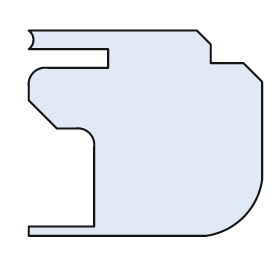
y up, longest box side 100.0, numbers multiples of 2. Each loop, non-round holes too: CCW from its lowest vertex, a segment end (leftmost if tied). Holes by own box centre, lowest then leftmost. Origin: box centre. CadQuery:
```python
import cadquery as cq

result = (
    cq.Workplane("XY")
    .moveTo(-50.0, -44.0)
    .lineTo(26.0, -44.0)
    .threePointArc((42.0, -36.0), (50.0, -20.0))
    .lineTo(50.0, 22.0)
    .lineTo(42.0, 30.0)
    .lineTo(28.0, 30.0)
    .lineTo(28.0, 38.0)
    .lineTo(22.0, 44.0)
    .lineTo(-50.0, 44.0)
    .threePointArc((-48.0, 40.0), (-50.0, 36.0))
    .lineTo(-16.0, 36.0)
    .lineTo(-16.0, 28.0)
    .lineTo(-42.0, 28.0)
    .threePointArc((-48.0, 26.0), (-50.0, 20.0))
    .lineTo(-50.0, 14.0)
    .lineTo(-38.0, 2.0)
    .lineTo(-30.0, 2.0)
    .threePointArc((-24.0, 0.0), (-22.0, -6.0))
    .lineTo(-22.0, -40.0)
    .lineTo(-50.0, -40.0)
    .close()
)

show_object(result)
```